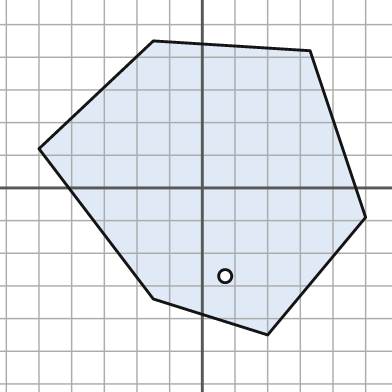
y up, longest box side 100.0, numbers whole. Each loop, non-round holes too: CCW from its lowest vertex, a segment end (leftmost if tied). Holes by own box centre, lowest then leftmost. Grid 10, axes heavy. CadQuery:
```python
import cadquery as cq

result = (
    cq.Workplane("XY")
    .moveTo(20.0, -45.0)
    .lineTo(50.0, -9.0)
    .lineTo(33.0, 42.0)
    .lineTo(-15.0, 45.0)
    .lineTo(-50.0, 12.0)
    .lineTo(-15.0, -34.0)
    .close()
    .moveTo(7.0, -27.0)
    .circle(2.0)
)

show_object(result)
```